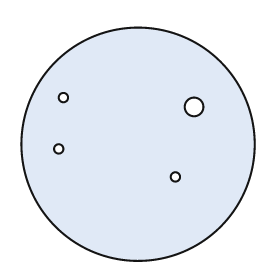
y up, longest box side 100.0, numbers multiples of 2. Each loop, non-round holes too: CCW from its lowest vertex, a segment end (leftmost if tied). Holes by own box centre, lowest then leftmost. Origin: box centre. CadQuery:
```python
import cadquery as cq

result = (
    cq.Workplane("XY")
    .moveTo(0.0, 0.0)
    .circle(50.0)
    .moveTo(16.0, -14.0)
    .circle(2.0)
    .moveTo(-34.0, -2.0)
    .circle(2.0)
    .moveTo(24.0, 16.0)
    .circle(4.0)
    .moveTo(-32.0, 20.0)
    .circle(2.0)
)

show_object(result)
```